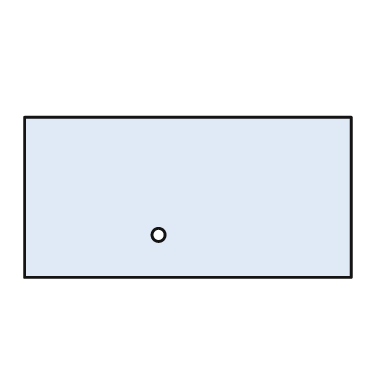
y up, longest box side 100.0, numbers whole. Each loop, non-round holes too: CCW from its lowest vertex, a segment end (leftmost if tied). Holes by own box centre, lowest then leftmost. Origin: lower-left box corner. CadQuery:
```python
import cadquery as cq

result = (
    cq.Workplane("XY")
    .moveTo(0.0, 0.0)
    .lineTo(100.0, 0.0)
    .lineTo(100.0, 49.0)
    .lineTo(0.0, 49.0)
    .close()
    .moveTo(41.0, 13.0)
    .circle(2.0)
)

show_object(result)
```